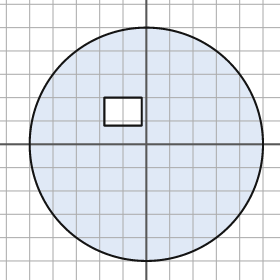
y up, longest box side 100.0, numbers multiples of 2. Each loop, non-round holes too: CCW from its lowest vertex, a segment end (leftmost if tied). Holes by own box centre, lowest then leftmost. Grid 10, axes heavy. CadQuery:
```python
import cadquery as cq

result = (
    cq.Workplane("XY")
    .moveTo(0.0, 0.0)
    .circle(50.0)
    .moveTo(-18.0, 8.0)
    .lineTo(-2.0, 8.0)
    .lineTo(-2.0, 20.0)
    .lineTo(-18.0, 20.0)
    .close()
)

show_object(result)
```